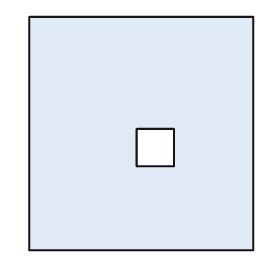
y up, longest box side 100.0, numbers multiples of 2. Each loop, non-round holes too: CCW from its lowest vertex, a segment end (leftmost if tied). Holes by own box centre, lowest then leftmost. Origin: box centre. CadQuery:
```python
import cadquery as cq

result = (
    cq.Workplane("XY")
    .moveTo(-48.0, -50.0)
    .lineTo(48.0, -50.0)
    .lineTo(48.0, 50.0)
    .lineTo(-48.0, 50.0)
    .close()
    .moveTo(-2.0, -14.0)
    .lineTo(14.0, -14.0)
    .lineTo(14.0, 2.0)
    .lineTo(-2.0, 2.0)
    .close()
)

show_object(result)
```